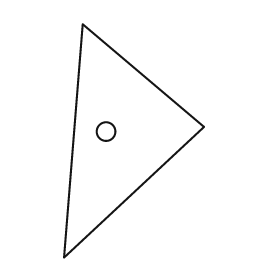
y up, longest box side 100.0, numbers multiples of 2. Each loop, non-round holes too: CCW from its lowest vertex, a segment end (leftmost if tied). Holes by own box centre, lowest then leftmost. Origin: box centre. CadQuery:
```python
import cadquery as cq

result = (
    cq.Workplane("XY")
    .moveTo(-30.0, -50.0)
    .lineTo(30.0, 6.0)
    .lineTo(-22.0, 50.0)
    .close()
    .moveTo(-12.0, 4.0)
    .circle(4.0)
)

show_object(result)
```